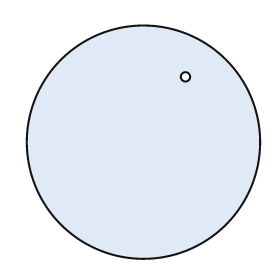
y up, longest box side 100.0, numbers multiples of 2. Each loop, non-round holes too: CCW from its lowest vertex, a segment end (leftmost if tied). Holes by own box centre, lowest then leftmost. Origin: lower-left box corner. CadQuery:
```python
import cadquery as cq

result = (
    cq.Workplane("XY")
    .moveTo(50.0, 50.0)
    .circle(50.0)
    .moveTo(68.0, 78.0)
    .circle(2.0)
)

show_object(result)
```